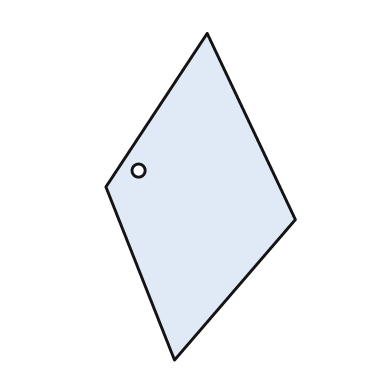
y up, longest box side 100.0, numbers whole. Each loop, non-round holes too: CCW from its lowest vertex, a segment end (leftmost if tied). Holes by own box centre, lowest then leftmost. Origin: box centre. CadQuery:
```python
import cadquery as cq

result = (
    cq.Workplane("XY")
    .moveTo(-8.0, -50.0)
    .lineTo(29.0, -7.0)
    .lineTo(2.0, 50.0)
    .lineTo(-29.0, 3.0)
    .close()
    .moveTo(-19.0, 8.0)
    .circle(2.0)
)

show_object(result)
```